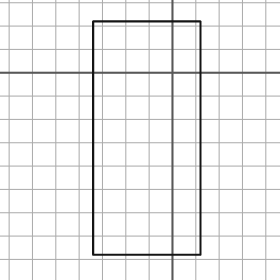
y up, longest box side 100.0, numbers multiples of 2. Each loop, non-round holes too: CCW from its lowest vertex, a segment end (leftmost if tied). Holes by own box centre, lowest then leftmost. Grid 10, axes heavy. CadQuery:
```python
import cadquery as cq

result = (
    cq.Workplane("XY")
    .moveTo(-34.0, -78.0)
    .lineTo(12.0, -78.0)
    .lineTo(12.0, 22.0)
    .lineTo(-34.0, 22.0)
    .close()
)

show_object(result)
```